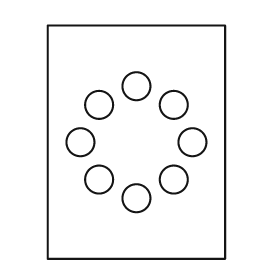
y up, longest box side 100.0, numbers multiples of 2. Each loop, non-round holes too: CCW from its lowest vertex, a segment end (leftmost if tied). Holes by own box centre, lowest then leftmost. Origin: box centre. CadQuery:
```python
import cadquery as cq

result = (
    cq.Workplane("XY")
    .moveTo(-38.0, -50.0)
    .lineTo(38.0, -50.0)
    .lineTo(38.0, 50.0)
    .lineTo(-38.0, 50.0)
    .close()
    .moveTo(0.0, -24.0)
    .circle(6.0)
    .moveTo(-16.0, -16.0)
    .circle(6.0)
    .moveTo(16.0, -16.0)
    .circle(6.0)
    .moveTo(-24.0, 0.0)
    .circle(6.0)
    .moveTo(24.0, 0.0)
    .circle(6.0)
    .moveTo(-16.0, 16.0)
    .circle(6.0)
    .moveTo(16.0, 16.0)
    .circle(6.0)
    .moveTo(0.0, 24.0)
    .circle(6.0)
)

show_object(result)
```